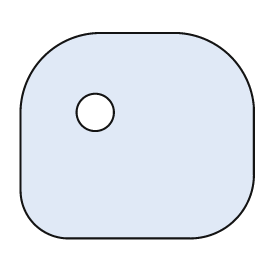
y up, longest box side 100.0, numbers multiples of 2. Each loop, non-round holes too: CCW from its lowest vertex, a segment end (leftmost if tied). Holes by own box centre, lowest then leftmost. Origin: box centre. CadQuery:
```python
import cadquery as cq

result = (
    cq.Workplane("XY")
    .moveTo(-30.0, -44.0)
    .lineTo(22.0, -44.0)
    .threePointArc((42.0, -36.0), (50.0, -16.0))
    .lineTo(50.0, 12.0)
    .threePointArc((40.0, 34.0), (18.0, 44.0))
    .lineTo(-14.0, 44.0)
    .threePointArc((-40.0, 34.0), (-50.0, 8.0))
    .lineTo(-50.0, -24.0)
    .threePointArc((-44.0, -38.0), (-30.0, -44.0))
    .close()
    .moveTo(-18.0, 10.0)
    .circle(8.0)
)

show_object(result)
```